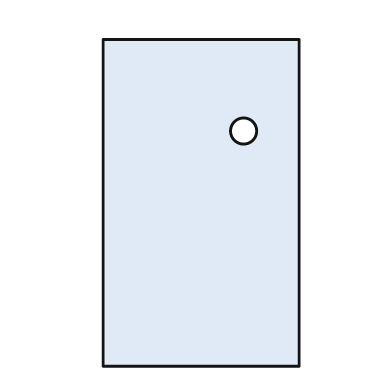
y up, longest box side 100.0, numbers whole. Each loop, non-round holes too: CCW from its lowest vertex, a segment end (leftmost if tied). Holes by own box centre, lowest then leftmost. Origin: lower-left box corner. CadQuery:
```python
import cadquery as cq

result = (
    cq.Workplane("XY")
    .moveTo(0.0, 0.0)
    .lineTo(60.0, 0.0)
    .lineTo(60.0, 100.0)
    .lineTo(0.0, 100.0)
    .close()
    .moveTo(43.0, 72.0)
    .circle(4.0)
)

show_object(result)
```